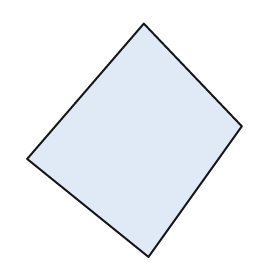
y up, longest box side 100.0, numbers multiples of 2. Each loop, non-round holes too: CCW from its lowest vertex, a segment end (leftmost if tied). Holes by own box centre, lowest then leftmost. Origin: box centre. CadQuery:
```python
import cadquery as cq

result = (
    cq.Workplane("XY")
    .moveTo(6.0, -50.0)
    .lineTo(46.0, 6.0)
    .lineTo(4.0, 50.0)
    .lineTo(-46.0, -8.0)
    .close()
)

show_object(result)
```